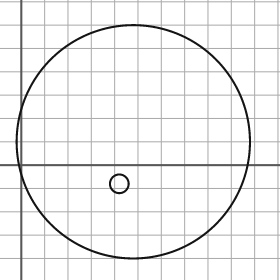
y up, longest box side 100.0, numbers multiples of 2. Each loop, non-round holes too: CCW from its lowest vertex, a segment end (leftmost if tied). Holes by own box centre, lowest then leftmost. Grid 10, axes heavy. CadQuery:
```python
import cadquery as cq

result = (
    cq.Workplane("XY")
    .moveTo(48.0, 10.0)
    .circle(50.0)
    .moveTo(42.0, -8.0)
    .circle(4.0)
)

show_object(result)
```